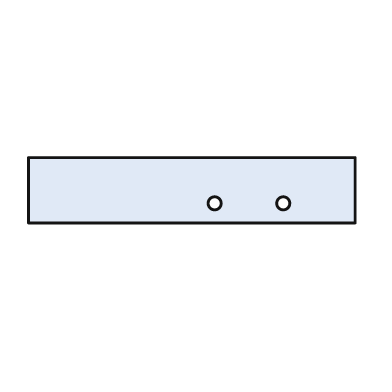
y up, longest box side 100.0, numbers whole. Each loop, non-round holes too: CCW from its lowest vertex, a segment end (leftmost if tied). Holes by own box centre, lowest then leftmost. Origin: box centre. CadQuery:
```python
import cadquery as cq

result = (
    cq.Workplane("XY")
    .moveTo(-50.0, -10.0)
    .lineTo(50.0, -10.0)
    .lineTo(50.0, 10.0)
    .lineTo(-50.0, 10.0)
    .close()
    .moveTo(7.0, -4.0)
    .circle(2.0)
    .moveTo(28.0, -4.0)
    .circle(2.0)
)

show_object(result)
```